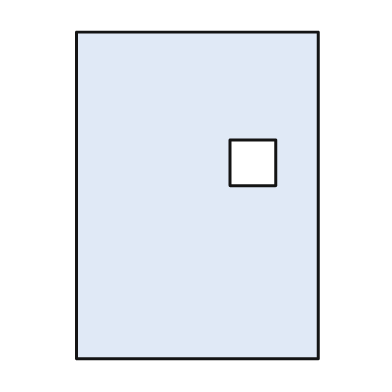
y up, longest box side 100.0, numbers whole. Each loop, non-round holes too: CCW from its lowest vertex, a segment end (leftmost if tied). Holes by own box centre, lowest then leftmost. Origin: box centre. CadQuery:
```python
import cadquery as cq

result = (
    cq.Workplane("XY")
    .moveTo(-37.0, -50.0)
    .lineTo(37.0, -50.0)
    .lineTo(37.0, 50.0)
    .lineTo(-37.0, 50.0)
    .close()
    .moveTo(10.0, 3.0)
    .lineTo(24.0, 3.0)
    .lineTo(24.0, 17.0)
    .lineTo(10.0, 17.0)
    .close()
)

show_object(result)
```